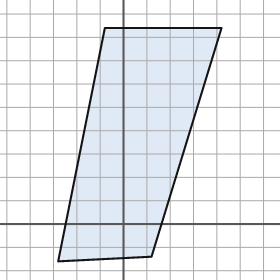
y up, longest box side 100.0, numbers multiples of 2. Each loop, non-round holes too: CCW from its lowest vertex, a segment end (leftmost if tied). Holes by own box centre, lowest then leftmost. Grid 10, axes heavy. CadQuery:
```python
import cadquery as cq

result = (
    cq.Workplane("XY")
    .moveTo(-28.0, -16.0)
    .lineTo(12.0, -14.0)
    .lineTo(42.0, 84.0)
    .lineTo(-8.0, 84.0)
    .close()
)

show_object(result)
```